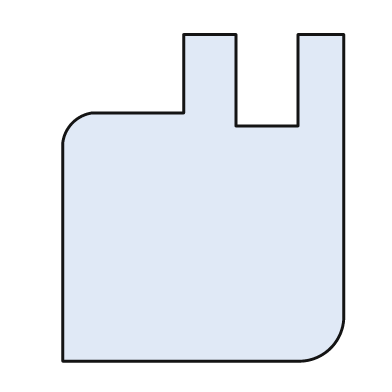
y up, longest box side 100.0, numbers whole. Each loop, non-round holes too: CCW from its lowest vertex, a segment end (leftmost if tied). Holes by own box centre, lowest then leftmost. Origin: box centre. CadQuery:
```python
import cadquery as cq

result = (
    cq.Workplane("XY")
    .moveTo(-43.0, -50.0)
    .lineTo(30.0, -50.0)
    .threePointArc((39.0, -46.0), (43.0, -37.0))
    .lineTo(43.0, 50.0)
    .lineTo(29.0, 50.0)
    .lineTo(29.0, 22.0)
    .lineTo(10.0, 22.0)
    .lineTo(10.0, 50.0)
    .lineTo(-6.0, 50.0)
    .lineTo(-6.0, 26.0)
    .lineTo(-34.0, 26.0)
    .threePointArc((-40.0, 23.0), (-43.0, 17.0))
    .close()
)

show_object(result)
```